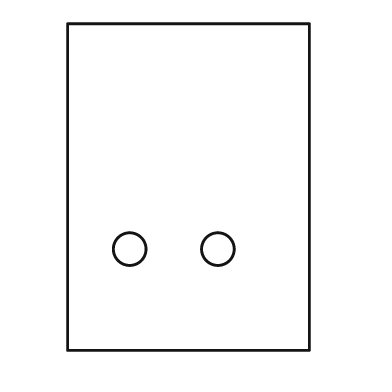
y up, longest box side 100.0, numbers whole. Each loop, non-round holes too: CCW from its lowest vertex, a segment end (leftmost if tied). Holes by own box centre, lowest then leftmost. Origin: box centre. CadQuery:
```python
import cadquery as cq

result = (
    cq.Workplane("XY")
    .moveTo(-37.0, -50.0)
    .lineTo(37.0, -50.0)
    .lineTo(37.0, 50.0)
    .lineTo(-37.0, 50.0)
    .close()
    .moveTo(-18.0, -19.0)
    .circle(5.0)
    .moveTo(9.0, -19.0)
    .circle(5.0)
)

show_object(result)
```